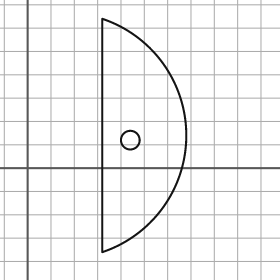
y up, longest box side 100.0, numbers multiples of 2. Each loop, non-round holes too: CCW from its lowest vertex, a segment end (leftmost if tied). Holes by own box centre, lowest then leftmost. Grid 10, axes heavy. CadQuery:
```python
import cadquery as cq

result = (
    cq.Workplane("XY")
    .moveTo(32.0, -36.0)
    .threePointArc((68.0, 14.0), (32.0, 64.0))
    .close()
    .moveTo(44.0, 12.0)
    .circle(4.0)
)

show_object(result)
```